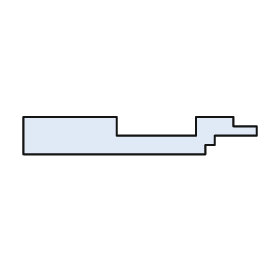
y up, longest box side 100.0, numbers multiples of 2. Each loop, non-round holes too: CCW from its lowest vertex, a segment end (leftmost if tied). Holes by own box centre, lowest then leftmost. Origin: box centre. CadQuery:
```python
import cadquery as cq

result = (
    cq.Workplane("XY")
    .moveTo(-50.0, -8.0)
    .lineTo(28.0, -8.0)
    .lineTo(28.0, -4.0)
    .lineTo(32.0, -4.0)
    .lineTo(32.0, 0.0)
    .lineTo(50.0, 0.0)
    .lineTo(50.0, 4.0)
    .lineTo(40.0, 4.0)
    .lineTo(40.0, 8.0)
    .lineTo(24.0, 8.0)
    .lineTo(24.0, 0.0)
    .lineTo(-10.0, 0.0)
    .lineTo(-10.0, 8.0)
    .lineTo(-50.0, 8.0)
    .close()
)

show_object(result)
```